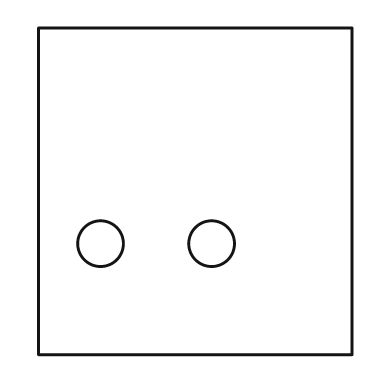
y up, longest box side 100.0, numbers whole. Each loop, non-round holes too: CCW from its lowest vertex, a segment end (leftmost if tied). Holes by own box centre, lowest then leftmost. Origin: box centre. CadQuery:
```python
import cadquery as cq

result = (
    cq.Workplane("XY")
    .moveTo(-48.0, -50.0)
    .lineTo(48.0, -50.0)
    .lineTo(48.0, 50.0)
    .lineTo(-48.0, 50.0)
    .close()
    .moveTo(-29.0, -16.0)
    .circle(7.0)
    .moveTo(5.0, -16.0)
    .circle(7.0)
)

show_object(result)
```